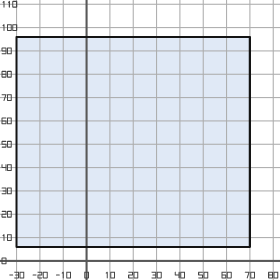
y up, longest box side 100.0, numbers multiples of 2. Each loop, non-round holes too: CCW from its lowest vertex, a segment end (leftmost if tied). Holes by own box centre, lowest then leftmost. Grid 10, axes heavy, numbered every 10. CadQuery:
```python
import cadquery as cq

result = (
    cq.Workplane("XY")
    .moveTo(-30.0, 6.0)
    .lineTo(70.0, 6.0)
    .lineTo(70.0, 96.0)
    .lineTo(-30.0, 96.0)
    .close()
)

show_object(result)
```